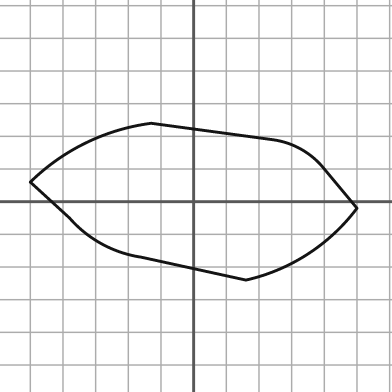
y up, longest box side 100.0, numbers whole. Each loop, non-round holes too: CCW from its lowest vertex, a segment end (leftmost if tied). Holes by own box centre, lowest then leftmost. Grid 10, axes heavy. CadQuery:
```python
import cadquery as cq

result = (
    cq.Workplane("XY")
    .moveTo(16.0, -24.0)
    .threePointArc((35.0, -16.0), (50.0, -2.0))
    .lineTo(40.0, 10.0)
    .threePointArc((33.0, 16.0), (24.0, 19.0))
    .lineTo(-13.0, 24.0)
    .threePointArc((-33.0, 18.0), (-50.0, 6.0))
    .lineTo(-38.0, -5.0)
    .threePointArc((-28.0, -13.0), (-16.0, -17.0))
    .close()
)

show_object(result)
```